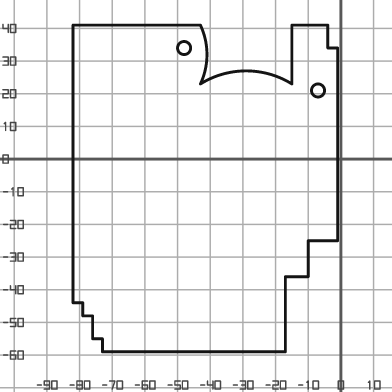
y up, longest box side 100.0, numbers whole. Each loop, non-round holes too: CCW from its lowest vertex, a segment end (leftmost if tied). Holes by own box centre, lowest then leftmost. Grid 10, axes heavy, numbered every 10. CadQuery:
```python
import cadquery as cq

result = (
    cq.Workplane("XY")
    .moveTo(-73.0, -59.0)
    .lineTo(-17.0, -59.0)
    .lineTo(-17.0, -36.0)
    .lineTo(-10.0, -36.0)
    .lineTo(-10.0, -25.0)
    .lineTo(-1.0, -25.0)
    .lineTo(-1.0, 34.0)
    .lineTo(-4.0, 34.0)
    .lineTo(-4.0, 41.0)
    .lineTo(-15.0, 41.0)
    .lineTo(-15.0, 23.0)
    .threePointArc((-29.0, 27.0), (-43.0, 23.0))
    .threePointArc((-41.0, 32.0), (-43.0, 41.0))
    .lineTo(-82.0, 41.0)
    .lineTo(-82.0, -44.0)
    .lineTo(-79.0, -44.0)
    .lineTo(-79.0, -48.0)
    .lineTo(-76.0, -48.0)
    .lineTo(-76.0, -55.0)
    .lineTo(-73.0, -55.0)
    .close()
    .moveTo(-7.0, 21.0)
    .circle(2.0)
    .moveTo(-48.0, 34.0)
    .circle(2.0)
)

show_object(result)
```